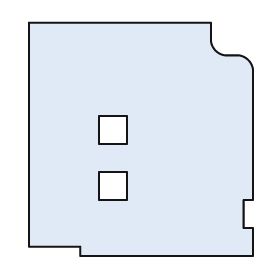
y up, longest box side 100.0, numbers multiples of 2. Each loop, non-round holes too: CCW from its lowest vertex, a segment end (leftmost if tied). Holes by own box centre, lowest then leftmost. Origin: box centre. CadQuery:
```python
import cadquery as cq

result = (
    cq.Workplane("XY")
    .moveTo(-26.0, -50.0)
    .lineTo(48.0, -50.0)
    .lineTo(48.0, -38.0)
    .lineTo(44.0, -38.0)
    .lineTo(44.0, -26.0)
    .lineTo(48.0, -26.0)
    .lineTo(48.0, 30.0)
    .threePointArc((46.0, 34.0), (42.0, 36.0))
    .lineTo(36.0, 36.0)
    .threePointArc((32.0, 38.0), (30.0, 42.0))
    .lineTo(30.0, 50.0)
    .lineTo(-48.0, 50.0)
    .lineTo(-48.0, -46.0)
    .lineTo(-26.0, -46.0)
    .close()
    .moveTo(-18.0, -26.0)
    .lineTo(-6.0, -26.0)
    .lineTo(-6.0, -14.0)
    .lineTo(-18.0, -14.0)
    .close()
    .moveTo(-18.0, -2.0)
    .lineTo(-6.0, -2.0)
    .lineTo(-6.0, 10.0)
    .lineTo(-18.0, 10.0)
    .close()
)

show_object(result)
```